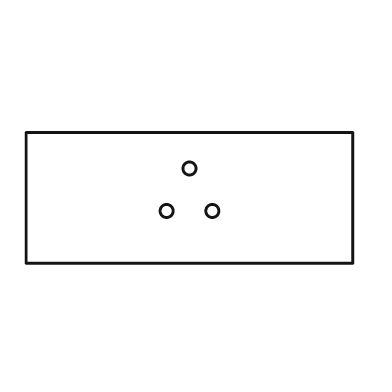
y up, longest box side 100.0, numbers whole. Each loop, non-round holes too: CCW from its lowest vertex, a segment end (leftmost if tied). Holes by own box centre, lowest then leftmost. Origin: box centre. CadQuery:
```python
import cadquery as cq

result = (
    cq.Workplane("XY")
    .moveTo(-50.0, -20.0)
    .lineTo(50.0, -20.0)
    .lineTo(50.0, 20.0)
    .lineTo(-50.0, 20.0)
    .close()
    .moveTo(-7.0, -4.0)
    .circle(2.0)
    .moveTo(7.0, -4.0)
    .circle(2.0)
    .moveTo(0.0, 9.0)
    .circle(2.0)
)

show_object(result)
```